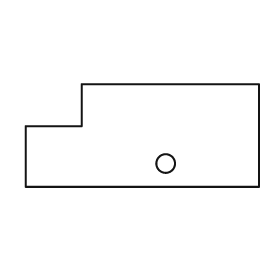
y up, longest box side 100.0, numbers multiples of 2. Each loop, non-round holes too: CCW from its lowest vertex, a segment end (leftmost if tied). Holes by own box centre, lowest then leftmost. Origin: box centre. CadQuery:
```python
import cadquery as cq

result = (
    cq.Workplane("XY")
    .moveTo(-50.0, -22.0)
    .lineTo(50.0, -22.0)
    .lineTo(50.0, 22.0)
    .lineTo(-26.0, 22.0)
    .lineTo(-26.0, 4.0)
    .lineTo(-50.0, 4.0)
    .close()
    .moveTo(10.0, -12.0)
    .circle(4.0)
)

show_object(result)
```